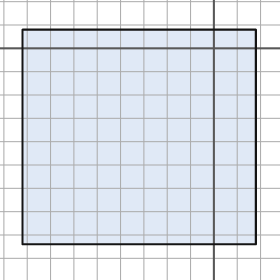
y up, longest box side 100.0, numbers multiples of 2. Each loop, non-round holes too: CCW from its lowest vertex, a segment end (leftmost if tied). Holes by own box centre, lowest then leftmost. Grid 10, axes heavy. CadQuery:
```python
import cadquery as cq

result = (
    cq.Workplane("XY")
    .moveTo(-82.0, -84.0)
    .lineTo(18.0, -84.0)
    .lineTo(18.0, 8.0)
    .lineTo(-82.0, 8.0)
    .close()
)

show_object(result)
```